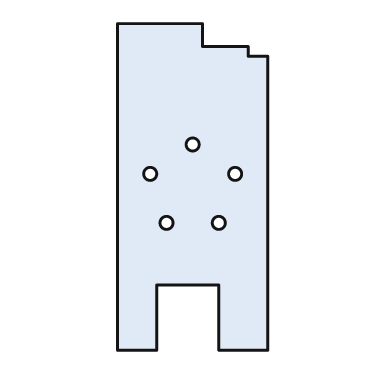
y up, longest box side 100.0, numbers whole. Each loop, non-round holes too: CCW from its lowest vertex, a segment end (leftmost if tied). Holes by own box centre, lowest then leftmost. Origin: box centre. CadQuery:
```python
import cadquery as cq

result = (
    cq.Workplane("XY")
    .moveTo(-23.0, -50.0)
    .lineTo(-11.0, -50.0)
    .lineTo(-11.0, -30.0)
    .lineTo(8.0, -30.0)
    .lineTo(8.0, -50.0)
    .lineTo(23.0, -50.0)
    .lineTo(23.0, 40.0)
    .lineTo(17.0, 40.0)
    .lineTo(17.0, 43.0)
    .lineTo(3.0, 43.0)
    .lineTo(3.0, 50.0)
    .lineTo(-23.0, 50.0)
    .close()
    .moveTo(-8.0, -11.0)
    .circle(2.0)
    .moveTo(8.0, -11.0)
    .circle(2.0)
    .moveTo(-13.0, 4.0)
    .circle(2.0)
    .moveTo(13.0, 4.0)
    .circle(2.0)
    .moveTo(0.0, 13.0)
    .circle(2.0)
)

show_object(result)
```